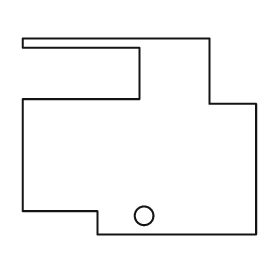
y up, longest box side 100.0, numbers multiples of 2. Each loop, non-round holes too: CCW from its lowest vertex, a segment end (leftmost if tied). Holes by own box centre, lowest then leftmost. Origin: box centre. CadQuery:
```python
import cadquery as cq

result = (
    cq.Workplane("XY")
    .moveTo(-18.0, -42.0)
    .lineTo(50.0, -42.0)
    .lineTo(50.0, 14.0)
    .lineTo(30.0, 14.0)
    .lineTo(30.0, 42.0)
    .lineTo(-50.0, 42.0)
    .lineTo(-50.0, 38.0)
    .lineTo(0.0, 38.0)
    .lineTo(0.0, 16.0)
    .lineTo(-50.0, 16.0)
    .lineTo(-50.0, -32.0)
    .lineTo(-18.0, -32.0)
    .close()
    .moveTo(2.0, -34.0)
    .circle(4.0)
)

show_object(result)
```